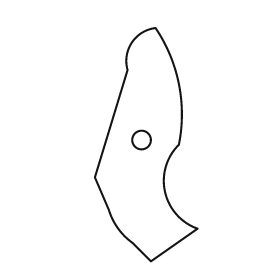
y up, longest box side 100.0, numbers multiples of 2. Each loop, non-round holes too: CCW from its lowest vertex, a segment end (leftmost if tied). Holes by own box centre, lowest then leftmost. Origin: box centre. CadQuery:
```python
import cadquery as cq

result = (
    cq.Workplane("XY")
    .moveTo(2.0, -50.0)
    .lineTo(22.0, -36.0)
    .threePointArc((8.0, -20.0), (14.0, 0.0))
    .threePointArc((14.0, 26.0), (4.0, 50.0))
    .threePointArc((-6.0, 44.0), (-8.0, 32.0))
    .lineTo(-22.0, -14.0)
    .lineTo(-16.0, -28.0)
    .threePointArc((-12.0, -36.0), (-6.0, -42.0))
    .close()
    .moveTo(-2.0, 2.0)
    .circle(4.0)
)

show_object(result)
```